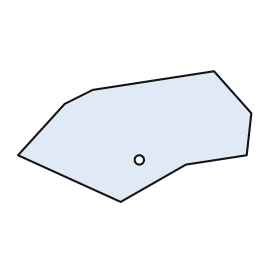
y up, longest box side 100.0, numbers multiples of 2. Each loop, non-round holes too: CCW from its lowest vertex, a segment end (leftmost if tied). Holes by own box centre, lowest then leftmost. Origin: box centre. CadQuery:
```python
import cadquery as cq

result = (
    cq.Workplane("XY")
    .moveTo(-6.0, -28.0)
    .lineTo(22.0, -12.0)
    .lineTo(48.0, -8.0)
    .lineTo(50.0, 10.0)
    .lineTo(34.0, 28.0)
    .lineTo(-18.0, 20.0)
    .lineTo(-30.0, 14.0)
    .lineTo(-50.0, -8.0)
    .close()
    .moveTo(2.0, -10.0)
    .circle(2.0)
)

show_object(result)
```